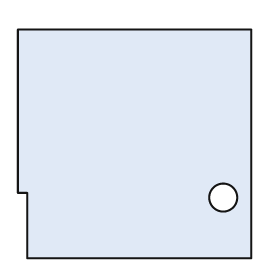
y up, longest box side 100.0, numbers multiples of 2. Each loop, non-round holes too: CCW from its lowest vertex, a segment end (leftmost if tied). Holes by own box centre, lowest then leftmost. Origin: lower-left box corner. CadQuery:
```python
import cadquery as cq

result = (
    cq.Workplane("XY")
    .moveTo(4.0, 0.0)
    .lineTo(100.0, 0.0)
    .lineTo(100.0, 98.0)
    .lineTo(0.0, 98.0)
    .lineTo(0.0, 28.0)
    .lineTo(4.0, 28.0)
    .close()
    .moveTo(88.0, 26.0)
    .circle(6.0)
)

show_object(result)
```